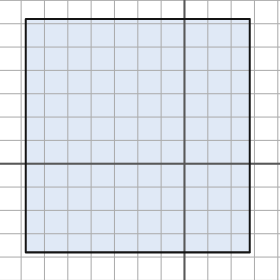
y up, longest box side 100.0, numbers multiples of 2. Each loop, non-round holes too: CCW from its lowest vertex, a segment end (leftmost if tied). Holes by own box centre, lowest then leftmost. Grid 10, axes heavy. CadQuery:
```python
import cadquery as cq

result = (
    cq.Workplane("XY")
    .moveTo(-68.0, -38.0)
    .lineTo(28.0, -38.0)
    .lineTo(28.0, 62.0)
    .lineTo(-68.0, 62.0)
    .close()
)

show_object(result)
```